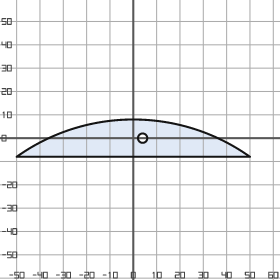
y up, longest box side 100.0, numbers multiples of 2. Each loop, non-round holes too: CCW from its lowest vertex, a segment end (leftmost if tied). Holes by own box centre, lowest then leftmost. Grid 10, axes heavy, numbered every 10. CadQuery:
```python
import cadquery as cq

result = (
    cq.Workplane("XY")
    .moveTo(-50.0, -8.0)
    .lineTo(50.0, -8.0)
    .threePointArc((0.0, 8.0), (-50.0, -8.0))
    .close()
    .moveTo(4.0, 0.0)
    .circle(2.0)
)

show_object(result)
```